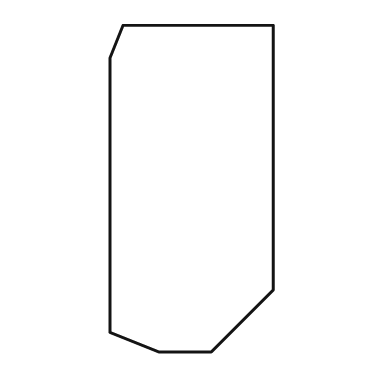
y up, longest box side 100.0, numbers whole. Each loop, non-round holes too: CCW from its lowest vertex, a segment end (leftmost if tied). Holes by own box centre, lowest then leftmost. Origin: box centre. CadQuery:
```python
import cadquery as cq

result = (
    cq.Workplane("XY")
    .moveTo(-10.0, -50.0)
    .lineTo(6.0, -50.0)
    .lineTo(25.0, -31.0)
    .lineTo(25.0, 50.0)
    .lineTo(-21.0, 50.0)
    .lineTo(-25.0, 40.0)
    .lineTo(-25.0, -44.0)
    .close()
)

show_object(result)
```